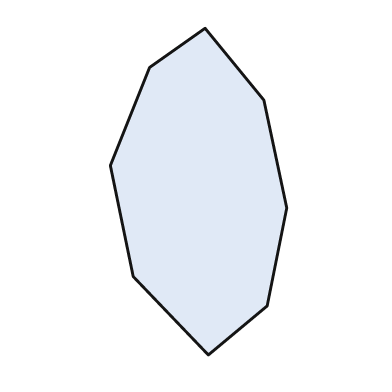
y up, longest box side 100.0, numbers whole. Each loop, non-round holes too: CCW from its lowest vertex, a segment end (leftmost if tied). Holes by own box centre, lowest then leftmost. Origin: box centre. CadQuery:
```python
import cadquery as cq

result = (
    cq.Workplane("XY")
    .moveTo(3.0, -50.0)
    .lineTo(21.0, -35.0)
    .lineTo(27.0, -5.0)
    .lineTo(20.0, 28.0)
    .lineTo(2.0, 50.0)
    .lineTo(-15.0, 38.0)
    .lineTo(-27.0, 8.0)
    .lineTo(-20.0, -26.0)
    .close()
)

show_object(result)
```